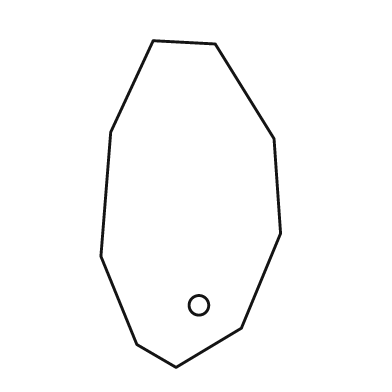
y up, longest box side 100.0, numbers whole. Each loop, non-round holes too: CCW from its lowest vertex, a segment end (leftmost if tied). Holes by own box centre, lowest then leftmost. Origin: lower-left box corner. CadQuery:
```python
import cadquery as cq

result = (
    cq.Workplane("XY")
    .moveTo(23.0, 0.0)
    .lineTo(43.0, 12.0)
    .lineTo(55.0, 41.0)
    .lineTo(53.0, 70.0)
    .lineTo(35.0, 99.0)
    .lineTo(16.0, 100.0)
    .lineTo(3.0, 72.0)
    .lineTo(0.0, 34.0)
    .lineTo(11.0, 7.0)
    .close()
    .moveTo(30.0, 19.0)
    .circle(3.0)
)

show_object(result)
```